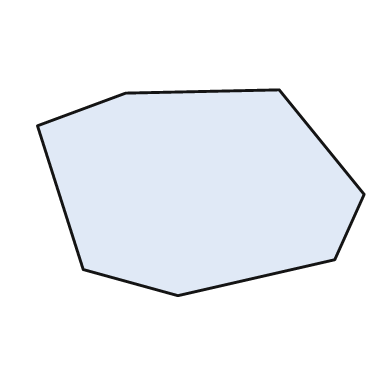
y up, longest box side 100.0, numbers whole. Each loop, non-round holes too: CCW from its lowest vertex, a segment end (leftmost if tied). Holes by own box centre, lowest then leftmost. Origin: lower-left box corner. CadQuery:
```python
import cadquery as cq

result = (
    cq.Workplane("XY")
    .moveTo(43.0, 0.0)
    .lineTo(91.0, 11.0)
    .lineTo(100.0, 31.0)
    .lineTo(74.0, 63.0)
    .lineTo(27.0, 62.0)
    .lineTo(0.0, 52.0)
    .lineTo(14.0, 8.0)
    .close()
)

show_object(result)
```